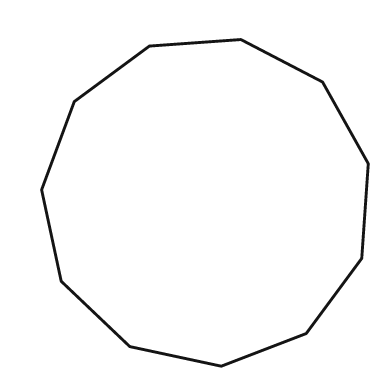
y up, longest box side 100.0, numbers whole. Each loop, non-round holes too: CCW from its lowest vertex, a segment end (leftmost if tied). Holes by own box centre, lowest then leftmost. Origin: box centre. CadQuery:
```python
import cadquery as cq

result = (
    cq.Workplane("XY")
    .moveTo(5.0, -50.0)
    .lineTo(31.0, -40.0)
    .lineTo(48.0, -17.0)
    .lineTo(50.0, 12.0)
    .lineTo(36.0, 37.0)
    .lineTo(11.0, 50.0)
    .lineTo(-17.0, 48.0)
    .lineTo(-40.0, 31.0)
    .lineTo(-50.0, 4.0)
    .lineTo(-44.0, -24.0)
    .lineTo(-23.0, -44.0)
    .close()
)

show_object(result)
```